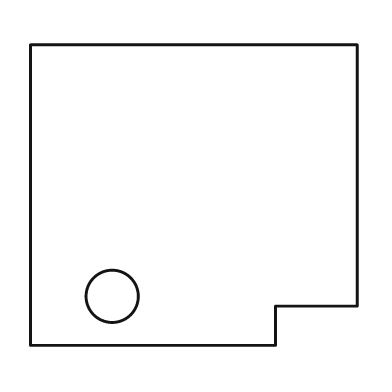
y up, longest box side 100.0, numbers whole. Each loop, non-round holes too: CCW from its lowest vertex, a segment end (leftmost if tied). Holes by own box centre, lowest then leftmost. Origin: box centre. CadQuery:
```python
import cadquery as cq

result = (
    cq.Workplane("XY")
    .moveTo(-50.0, -46.0)
    .lineTo(25.0, -46.0)
    .lineTo(25.0, -34.0)
    .lineTo(50.0, -34.0)
    .lineTo(50.0, 46.0)
    .lineTo(-50.0, 46.0)
    .close()
    .moveTo(-25.0, -31.0)
    .circle(8.0)
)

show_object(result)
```